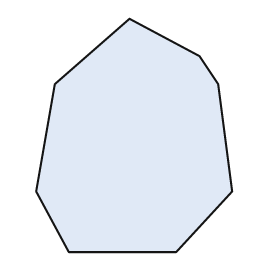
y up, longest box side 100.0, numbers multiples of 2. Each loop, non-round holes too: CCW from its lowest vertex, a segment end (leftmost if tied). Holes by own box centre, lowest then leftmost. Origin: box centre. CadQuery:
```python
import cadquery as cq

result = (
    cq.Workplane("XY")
    .moveTo(-28.0, -50.0)
    .lineTo(18.0, -50.0)
    .lineTo(42.0, -24.0)
    .lineTo(36.0, 22.0)
    .lineTo(28.0, 34.0)
    .lineTo(-2.0, 50.0)
    .lineTo(-34.0, 22.0)
    .lineTo(-42.0, -24.0)
    .close()
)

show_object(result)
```